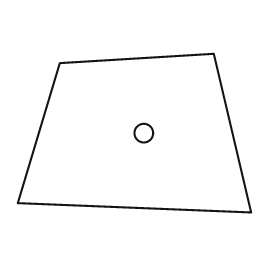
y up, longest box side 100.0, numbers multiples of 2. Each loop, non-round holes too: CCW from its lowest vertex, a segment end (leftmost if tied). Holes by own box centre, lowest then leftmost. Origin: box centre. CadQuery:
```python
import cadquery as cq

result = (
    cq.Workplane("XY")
    .moveTo(50.0, -34.0)
    .lineTo(34.0, 34.0)
    .lineTo(-32.0, 30.0)
    .lineTo(-50.0, -30.0)
    .close()
    .moveTo(4.0, 0.0)
    .circle(4.0)
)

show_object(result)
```